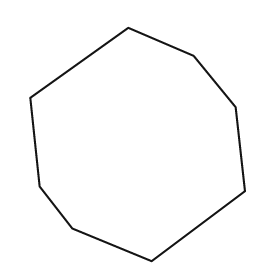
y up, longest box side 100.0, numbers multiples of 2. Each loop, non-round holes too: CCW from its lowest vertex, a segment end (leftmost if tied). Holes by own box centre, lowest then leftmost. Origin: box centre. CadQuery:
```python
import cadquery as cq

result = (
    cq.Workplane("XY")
    .moveTo(6.0, -50.0)
    .lineTo(46.0, -20.0)
    .lineTo(42.0, 16.0)
    .lineTo(24.0, 38.0)
    .lineTo(-4.0, 50.0)
    .lineTo(-46.0, 20.0)
    .lineTo(-42.0, -18.0)
    .lineTo(-28.0, -36.0)
    .close()
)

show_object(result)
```